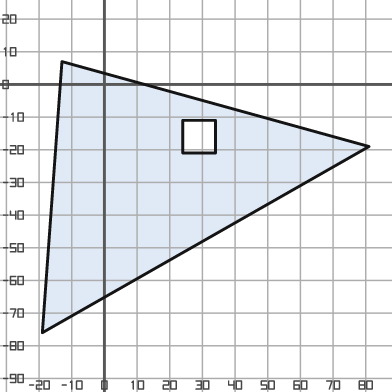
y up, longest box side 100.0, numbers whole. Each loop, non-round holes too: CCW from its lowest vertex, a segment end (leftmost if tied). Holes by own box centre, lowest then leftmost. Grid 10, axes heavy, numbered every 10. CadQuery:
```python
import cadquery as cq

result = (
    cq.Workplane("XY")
    .moveTo(-19.0, -76.0)
    .lineTo(81.0, -19.0)
    .lineTo(-13.0, 7.0)
    .close()
    .moveTo(24.0, -21.0)
    .lineTo(34.0, -21.0)
    .lineTo(34.0, -11.0)
    .lineTo(24.0, -11.0)
    .close()
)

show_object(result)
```